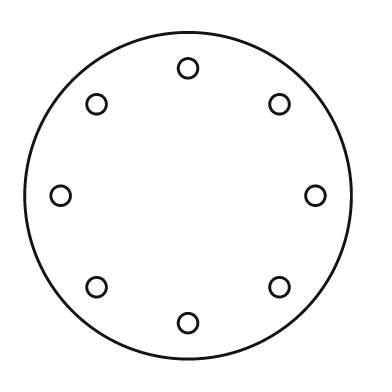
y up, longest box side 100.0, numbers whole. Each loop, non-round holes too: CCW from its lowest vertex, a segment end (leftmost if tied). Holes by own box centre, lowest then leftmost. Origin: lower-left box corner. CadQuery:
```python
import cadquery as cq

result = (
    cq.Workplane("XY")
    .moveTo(50.0, 50.0)
    .circle(50.0)
    .moveTo(50.0, 11.0)
    .circle(3.0)
    .moveTo(22.0, 22.0)
    .circle(3.0)
    .moveTo(78.0, 22.0)
    .circle(3.0)
    .moveTo(11.0, 50.0)
    .circle(3.0)
    .moveTo(89.0, 50.0)
    .circle(3.0)
    .moveTo(22.0, 78.0)
    .circle(3.0)
    .moveTo(78.0, 78.0)
    .circle(3.0)
    .moveTo(50.0, 89.0)
    .circle(3.0)
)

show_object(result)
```